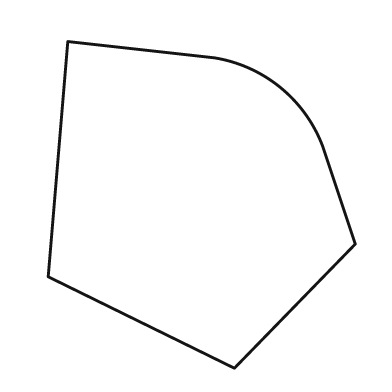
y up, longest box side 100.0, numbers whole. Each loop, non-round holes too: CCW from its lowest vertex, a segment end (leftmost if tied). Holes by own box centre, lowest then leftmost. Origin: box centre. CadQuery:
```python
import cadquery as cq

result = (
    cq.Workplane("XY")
    .moveTo(10.0, -50.0)
    .lineTo(47.0, -12.0)
    .lineTo(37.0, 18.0)
    .threePointArc((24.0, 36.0), (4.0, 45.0))
    .lineTo(-41.0, 50.0)
    .lineTo(-47.0, -22.0)
    .close()
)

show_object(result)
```